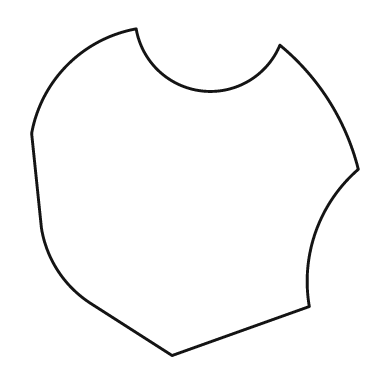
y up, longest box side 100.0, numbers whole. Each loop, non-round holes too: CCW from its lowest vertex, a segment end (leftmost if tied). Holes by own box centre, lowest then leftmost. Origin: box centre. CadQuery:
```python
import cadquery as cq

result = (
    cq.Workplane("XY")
    .moveTo(-7.0, -50.0)
    .lineTo(35.0, -35.0)
    .threePointArc((37.0, -12.0), (50.0, 7.0))
    .threePointArc((41.0, 28.0), (26.0, 45.0))
    .threePointArc((2.0, 31.0), (-18.0, 50.0))
    .threePointArc((-39.0, 39.0), (-50.0, 18.0))
    .lineTo(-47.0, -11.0)
    .threePointArc((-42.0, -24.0), (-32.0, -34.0))
    .close()
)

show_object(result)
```